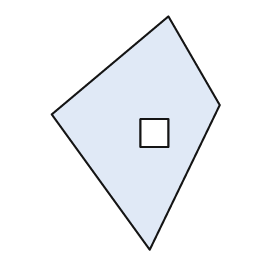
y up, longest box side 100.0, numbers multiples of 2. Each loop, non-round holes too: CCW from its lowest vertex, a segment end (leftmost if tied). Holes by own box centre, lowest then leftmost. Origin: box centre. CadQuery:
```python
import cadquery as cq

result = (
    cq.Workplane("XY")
    .moveTo(6.0, -50.0)
    .lineTo(36.0, 12.0)
    .lineTo(14.0, 50.0)
    .lineTo(-36.0, 8.0)
    .close()
    .moveTo(2.0, -6.0)
    .lineTo(14.0, -6.0)
    .lineTo(14.0, 6.0)
    .lineTo(2.0, 6.0)
    .close()
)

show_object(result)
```